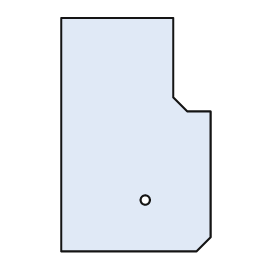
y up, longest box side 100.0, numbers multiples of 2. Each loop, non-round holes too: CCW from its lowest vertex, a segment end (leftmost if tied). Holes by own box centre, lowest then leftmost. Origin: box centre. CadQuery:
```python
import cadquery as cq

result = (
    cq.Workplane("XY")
    .moveTo(-32.0, -50.0)
    .lineTo(26.0, -50.0)
    .lineTo(32.0, -44.0)
    .lineTo(32.0, 10.0)
    .lineTo(22.0, 10.0)
    .lineTo(16.0, 16.0)
    .lineTo(16.0, 50.0)
    .lineTo(-32.0, 50.0)
    .close()
    .moveTo(4.0, -28.0)
    .circle(2.0)
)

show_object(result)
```